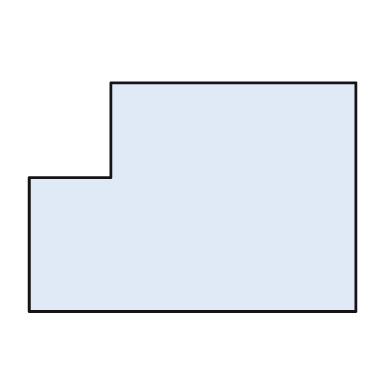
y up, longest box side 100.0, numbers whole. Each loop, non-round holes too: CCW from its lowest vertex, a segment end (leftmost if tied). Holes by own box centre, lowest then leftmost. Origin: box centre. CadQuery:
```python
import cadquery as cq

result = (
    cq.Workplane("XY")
    .moveTo(-50.0, -35.0)
    .lineTo(50.0, -35.0)
    .lineTo(50.0, 35.0)
    .lineTo(-25.0, 35.0)
    .lineTo(-25.0, 6.0)
    .lineTo(-50.0, 6.0)
    .close()
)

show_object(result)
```